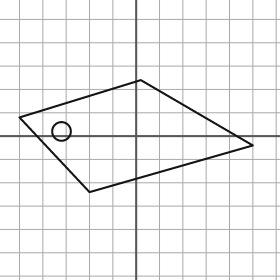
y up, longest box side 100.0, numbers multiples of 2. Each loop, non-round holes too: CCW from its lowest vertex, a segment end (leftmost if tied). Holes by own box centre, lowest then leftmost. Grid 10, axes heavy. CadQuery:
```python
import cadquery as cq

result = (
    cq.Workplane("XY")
    .moveTo(-20.0, -24.0)
    .lineTo(50.0, -4.0)
    .lineTo(2.0, 24.0)
    .lineTo(-50.0, 8.0)
    .close()
    .moveTo(-32.0, 2.0)
    .circle(4.0)
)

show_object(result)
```